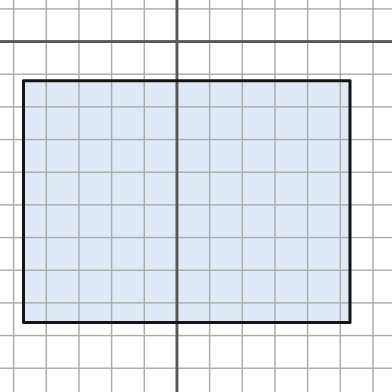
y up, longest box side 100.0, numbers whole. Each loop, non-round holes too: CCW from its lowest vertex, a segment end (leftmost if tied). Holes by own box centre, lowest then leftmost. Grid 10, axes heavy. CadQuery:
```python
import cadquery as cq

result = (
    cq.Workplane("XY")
    .moveTo(-47.0, -86.0)
    .lineTo(53.0, -86.0)
    .lineTo(53.0, -12.0)
    .lineTo(-47.0, -12.0)
    .close()
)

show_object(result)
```